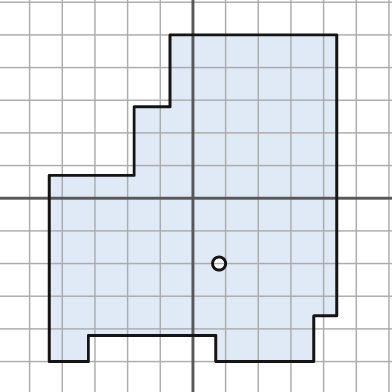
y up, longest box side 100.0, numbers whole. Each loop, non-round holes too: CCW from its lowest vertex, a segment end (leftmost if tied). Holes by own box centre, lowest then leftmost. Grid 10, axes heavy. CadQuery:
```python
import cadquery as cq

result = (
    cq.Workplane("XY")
    .moveTo(-44.0, -50.0)
    .lineTo(-32.0, -50.0)
    .lineTo(-32.0, -42.0)
    .lineTo(7.0, -42.0)
    .lineTo(7.0, -50.0)
    .lineTo(37.0, -50.0)
    .lineTo(37.0, -36.0)
    .lineTo(44.0, -36.0)
    .lineTo(44.0, 50.0)
    .lineTo(-7.0, 50.0)
    .lineTo(-7.0, 28.0)
    .lineTo(-18.0, 28.0)
    .lineTo(-18.0, 7.0)
    .lineTo(-44.0, 7.0)
    .close()
    .moveTo(8.0, -20.0)
    .circle(2.0)
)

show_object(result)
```